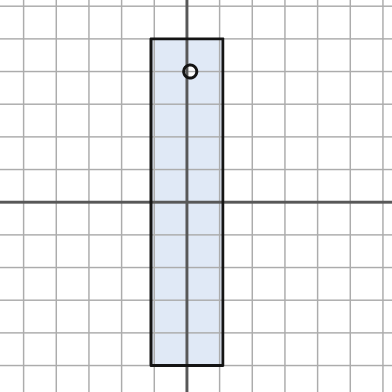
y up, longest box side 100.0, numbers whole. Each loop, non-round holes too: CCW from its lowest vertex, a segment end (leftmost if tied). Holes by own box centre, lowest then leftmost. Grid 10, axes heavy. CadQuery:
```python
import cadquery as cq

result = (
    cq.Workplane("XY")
    .moveTo(-11.0, -50.0)
    .lineTo(11.0, -50.0)
    .lineTo(11.0, 50.0)
    .lineTo(-11.0, 50.0)
    .close()
    .moveTo(1.0, 40.0)
    .circle(2.0)
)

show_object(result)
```